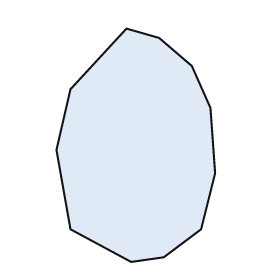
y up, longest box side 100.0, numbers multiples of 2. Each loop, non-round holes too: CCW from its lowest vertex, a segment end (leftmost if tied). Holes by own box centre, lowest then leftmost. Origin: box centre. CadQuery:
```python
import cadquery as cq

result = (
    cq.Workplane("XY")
    .moveTo(-2.0, -50.0)
    .lineTo(12.0, -48.0)
    .lineTo(28.0, -36.0)
    .lineTo(34.0, -12.0)
    .lineTo(32.0, 16.0)
    .lineTo(24.0, 34.0)
    .lineTo(10.0, 46.0)
    .lineTo(-4.0, 50.0)
    .lineTo(-28.0, 24.0)
    .lineTo(-34.0, -2.0)
    .lineTo(-28.0, -36.0)
    .close()
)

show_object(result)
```